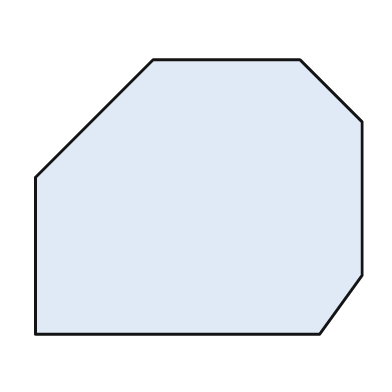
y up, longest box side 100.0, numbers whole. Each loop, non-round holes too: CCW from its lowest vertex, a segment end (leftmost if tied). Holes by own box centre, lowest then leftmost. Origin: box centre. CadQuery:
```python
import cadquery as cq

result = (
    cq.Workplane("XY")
    .moveTo(-50.0, -42.0)
    .lineTo(37.0, -42.0)
    .lineTo(50.0, -24.0)
    .lineTo(50.0, 23.0)
    .lineTo(31.0, 42.0)
    .lineTo(-14.0, 42.0)
    .lineTo(-50.0, 6.0)
    .close()
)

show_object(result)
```